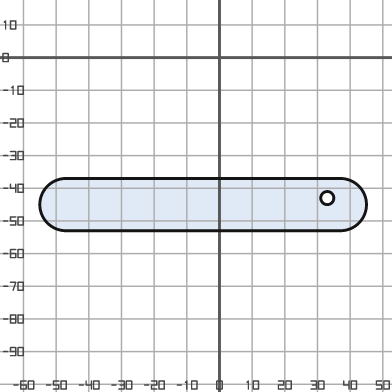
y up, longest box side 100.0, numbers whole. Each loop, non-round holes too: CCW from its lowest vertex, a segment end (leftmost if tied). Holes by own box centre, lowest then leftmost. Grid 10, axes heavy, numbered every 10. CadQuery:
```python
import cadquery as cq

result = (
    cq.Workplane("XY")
    .moveTo(-47.0, -53.0)
    .lineTo(37.0, -53.0)
    .threePointArc((45.0, -45.0), (37.0, -37.0))
    .lineTo(-47.0, -37.0)
    .threePointArc((-55.0, -45.0), (-47.0, -53.0))
    .close()
    .moveTo(33.0, -43.0)
    .circle(2.0)
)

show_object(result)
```